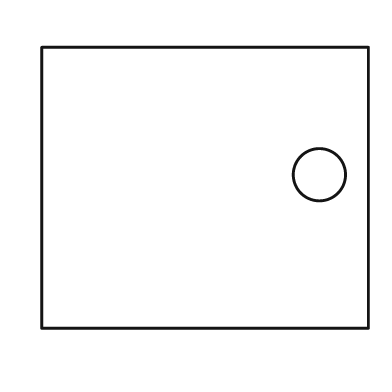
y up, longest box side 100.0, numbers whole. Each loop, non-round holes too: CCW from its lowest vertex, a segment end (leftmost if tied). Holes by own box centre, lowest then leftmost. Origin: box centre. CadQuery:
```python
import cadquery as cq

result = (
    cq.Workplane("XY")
    .moveTo(-50.0, -43.0)
    .lineTo(50.0, -43.0)
    .lineTo(50.0, 43.0)
    .lineTo(-50.0, 43.0)
    .close()
    .moveTo(35.0, 4.0)
    .circle(8.0)
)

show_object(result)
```